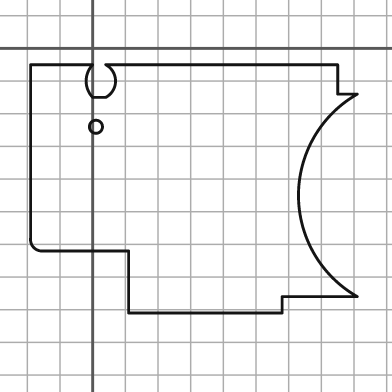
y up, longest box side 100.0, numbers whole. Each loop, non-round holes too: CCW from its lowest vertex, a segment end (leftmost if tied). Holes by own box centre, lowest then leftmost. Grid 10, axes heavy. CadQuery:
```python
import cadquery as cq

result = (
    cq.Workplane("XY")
    .moveTo(11.0, -81.0)
    .lineTo(58.0, -81.0)
    .lineTo(58.0, -76.0)
    .lineTo(81.0, -76.0)
    .threePointArc((63.0, -45.0), (81.0, -14.0))
    .lineTo(75.0, -14.0)
    .lineTo(75.0, -5.0)
    .lineTo(4.0, -5.0)
    .threePointArc((7.0, -10.0), (4.0, -15.0))
    .lineTo(0.0, -15.0)
    .threePointArc((-2.0, -10.0), (0.0, -5.0))
    .lineTo(-19.0, -5.0)
    .lineTo(-19.0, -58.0)
    .threePointArc((-18.0, -61.0), (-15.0, -62.0))
    .lineTo(11.0, -62.0)
    .close()
    .moveTo(1.0, -24.0)
    .circle(2.0)
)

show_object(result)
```